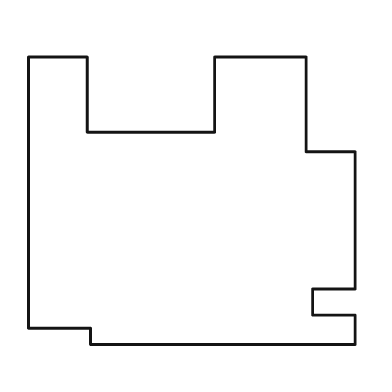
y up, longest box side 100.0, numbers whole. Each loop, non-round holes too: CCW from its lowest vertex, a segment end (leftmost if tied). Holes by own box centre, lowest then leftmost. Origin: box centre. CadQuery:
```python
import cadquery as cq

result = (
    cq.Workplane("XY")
    .moveTo(-31.0, -44.0)
    .lineTo(50.0, -44.0)
    .lineTo(50.0, -35.0)
    .lineTo(37.0, -35.0)
    .lineTo(37.0, -27.0)
    .lineTo(50.0, -27.0)
    .lineTo(50.0, 15.0)
    .lineTo(35.0, 15.0)
    .lineTo(35.0, 44.0)
    .lineTo(7.0, 44.0)
    .lineTo(7.0, 21.0)
    .lineTo(-32.0, 21.0)
    .lineTo(-32.0, 44.0)
    .lineTo(-50.0, 44.0)
    .lineTo(-50.0, -39.0)
    .lineTo(-31.0, -39.0)
    .close()
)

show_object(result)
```